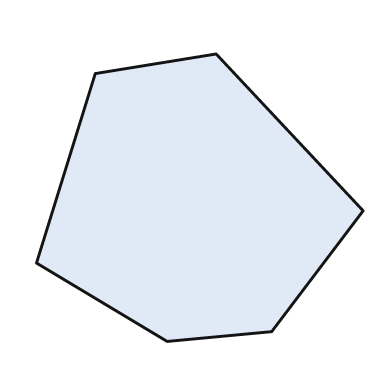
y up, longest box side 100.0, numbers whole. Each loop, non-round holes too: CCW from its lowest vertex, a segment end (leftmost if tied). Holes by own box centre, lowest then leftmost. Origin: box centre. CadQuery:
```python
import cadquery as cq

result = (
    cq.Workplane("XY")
    .moveTo(-10.0, -44.0)
    .lineTo(22.0, -41.0)
    .lineTo(50.0, -4.0)
    .lineTo(5.0, 44.0)
    .lineTo(-32.0, 38.0)
    .lineTo(-50.0, -20.0)
    .close()
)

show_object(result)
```